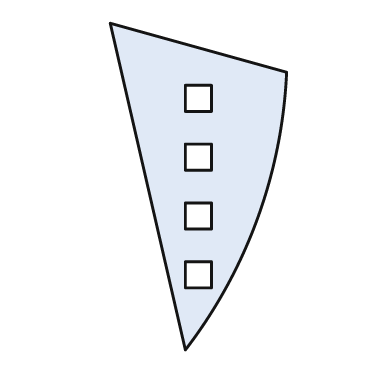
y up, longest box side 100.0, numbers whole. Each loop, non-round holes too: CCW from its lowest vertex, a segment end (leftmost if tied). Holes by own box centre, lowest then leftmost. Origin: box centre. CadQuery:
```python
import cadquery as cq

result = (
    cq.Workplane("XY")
    .moveTo(-4.0, -50.0)
    .threePointArc((18.0, -10.0), (27.0, 35.0))
    .lineTo(-27.0, 50.0)
    .close()
    .moveTo(-4.0, -31.0)
    .lineTo(4.0, -31.0)
    .lineTo(4.0, -23.0)
    .lineTo(-4.0, -23.0)
    .close()
    .moveTo(-4.0, -13.0)
    .lineTo(4.0, -13.0)
    .lineTo(4.0, -5.0)
    .lineTo(-4.0, -5.0)
    .close()
    .moveTo(-4.0, 5.0)
    .lineTo(4.0, 5.0)
    .lineTo(4.0, 13.0)
    .lineTo(-4.0, 13.0)
    .close()
    .moveTo(-4.0, 23.0)
    .lineTo(4.0, 23.0)
    .lineTo(4.0, 31.0)
    .lineTo(-4.0, 31.0)
    .close()
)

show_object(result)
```